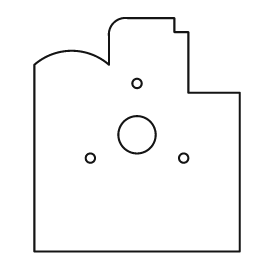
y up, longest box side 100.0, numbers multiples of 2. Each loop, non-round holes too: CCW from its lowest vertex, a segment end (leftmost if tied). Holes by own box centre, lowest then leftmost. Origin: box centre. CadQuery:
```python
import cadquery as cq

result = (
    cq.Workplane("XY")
    .moveTo(-44.0, -50.0)
    .lineTo(44.0, -50.0)
    .lineTo(44.0, 18.0)
    .lineTo(22.0, 18.0)
    .lineTo(22.0, 44.0)
    .lineTo(16.0, 44.0)
    .lineTo(16.0, 50.0)
    .lineTo(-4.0, 50.0)
    .threePointArc((-10.0, 48.0), (-12.0, 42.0))
    .lineTo(-12.0, 30.0)
    .threePointArc((-28.0, 36.0), (-44.0, 30.0))
    .close()
    .moveTo(-20.0, -10.0)
    .circle(2.0)
    .moveTo(20.0, -10.0)
    .circle(2.0)
    .moveTo(0.0, 0.0)
    .circle(8.0)
    .moveTo(0.0, 22.0)
    .circle(2.0)
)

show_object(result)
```